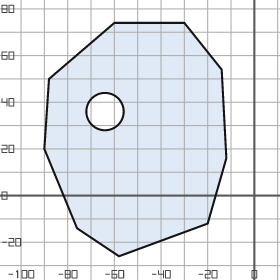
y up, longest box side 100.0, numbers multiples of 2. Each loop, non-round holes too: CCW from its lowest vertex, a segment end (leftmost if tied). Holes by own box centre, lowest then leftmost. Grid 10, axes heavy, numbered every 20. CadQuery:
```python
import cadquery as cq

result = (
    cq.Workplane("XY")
    .moveTo(-58.0, -26.0)
    .lineTo(-20.0, -12.0)
    .lineTo(-12.0, 16.0)
    .lineTo(-14.0, 54.0)
    .lineTo(-30.0, 74.0)
    .lineTo(-60.0, 74.0)
    .lineTo(-88.0, 50.0)
    .lineTo(-90.0, 20.0)
    .lineTo(-76.0, -14.0)
    .close()
    .moveTo(-64.0, 36.0)
    .circle(8.0)
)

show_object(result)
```